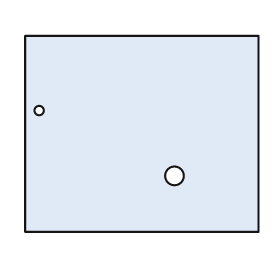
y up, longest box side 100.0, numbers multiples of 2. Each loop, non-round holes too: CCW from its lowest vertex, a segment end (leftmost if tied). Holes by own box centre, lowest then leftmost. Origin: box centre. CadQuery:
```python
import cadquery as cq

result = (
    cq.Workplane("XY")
    .moveTo(-50.0, -42.0)
    .lineTo(50.0, -42.0)
    .lineTo(50.0, 42.0)
    .lineTo(-50.0, 42.0)
    .close()
    .moveTo(14.0, -18.0)
    .circle(4.0)
    .moveTo(-44.0, 10.0)
    .circle(2.0)
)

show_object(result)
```